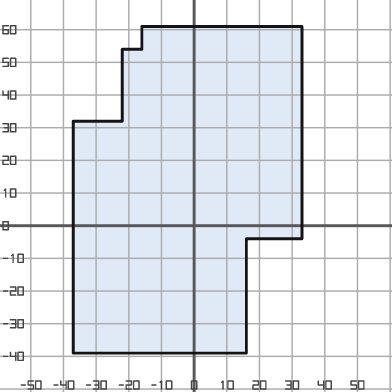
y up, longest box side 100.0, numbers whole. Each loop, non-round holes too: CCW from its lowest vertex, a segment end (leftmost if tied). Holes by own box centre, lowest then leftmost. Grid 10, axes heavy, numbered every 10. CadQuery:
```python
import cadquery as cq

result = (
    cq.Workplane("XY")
    .moveTo(-37.0, -39.0)
    .lineTo(16.0, -39.0)
    .lineTo(16.0, -4.0)
    .lineTo(33.0, -4.0)
    .lineTo(33.0, 61.0)
    .lineTo(-16.0, 61.0)
    .lineTo(-16.0, 54.0)
    .lineTo(-22.0, 54.0)
    .lineTo(-22.0, 32.0)
    .lineTo(-37.0, 32.0)
    .close()
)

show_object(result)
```